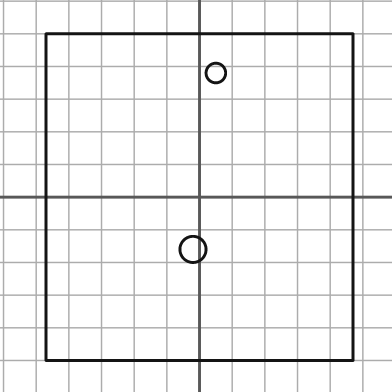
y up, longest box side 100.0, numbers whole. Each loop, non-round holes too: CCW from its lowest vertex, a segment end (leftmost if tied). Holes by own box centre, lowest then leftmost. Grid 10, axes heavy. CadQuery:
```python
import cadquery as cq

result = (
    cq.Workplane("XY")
    .moveTo(-47.0, -50.0)
    .lineTo(47.0, -50.0)
    .lineTo(47.0, 50.0)
    .lineTo(-47.0, 50.0)
    .close()
    .moveTo(-2.0, -16.0)
    .circle(4.0)
    .moveTo(5.0, 38.0)
    .circle(3.0)
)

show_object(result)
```